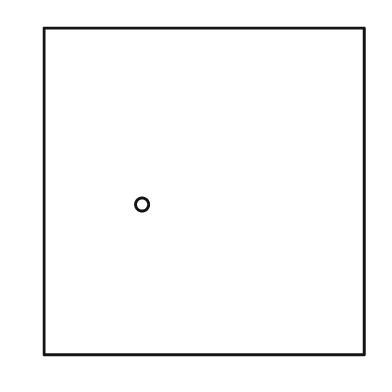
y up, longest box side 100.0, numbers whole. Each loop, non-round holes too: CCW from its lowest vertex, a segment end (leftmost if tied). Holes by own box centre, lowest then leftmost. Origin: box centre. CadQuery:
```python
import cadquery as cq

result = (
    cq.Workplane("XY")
    .moveTo(-49.0, -50.0)
    .lineTo(49.0, -50.0)
    .lineTo(49.0, 50.0)
    .lineTo(-49.0, 50.0)
    .close()
    .moveTo(-19.0, -4.0)
    .circle(2.0)
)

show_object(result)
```